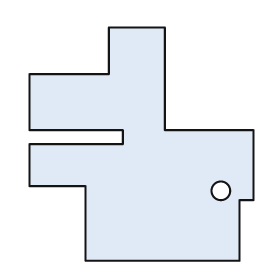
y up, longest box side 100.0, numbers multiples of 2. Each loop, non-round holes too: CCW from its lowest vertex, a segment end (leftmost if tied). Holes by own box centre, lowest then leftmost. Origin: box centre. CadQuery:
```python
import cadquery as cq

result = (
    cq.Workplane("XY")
    .moveTo(-24.0, -50.0)
    .lineTo(42.0, -50.0)
    .lineTo(42.0, -24.0)
    .lineTo(48.0, -24.0)
    .lineTo(48.0, 6.0)
    .lineTo(10.0, 6.0)
    .lineTo(10.0, 50.0)
    .lineTo(-14.0, 50.0)
    .lineTo(-14.0, 30.0)
    .lineTo(-48.0, 30.0)
    .lineTo(-48.0, 6.0)
    .lineTo(-8.0, 6.0)
    .lineTo(-8.0, 0.0)
    .lineTo(-48.0, 0.0)
    .lineTo(-48.0, -18.0)
    .lineTo(-24.0, -18.0)
    .close()
    .moveTo(34.0, -20.0)
    .circle(4.0)
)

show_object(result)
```